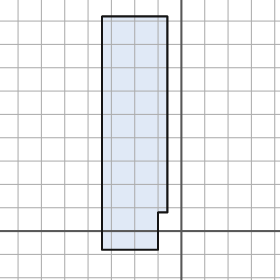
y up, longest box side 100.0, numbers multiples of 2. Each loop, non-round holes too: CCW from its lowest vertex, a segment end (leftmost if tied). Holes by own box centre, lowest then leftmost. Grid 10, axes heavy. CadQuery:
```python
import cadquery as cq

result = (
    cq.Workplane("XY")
    .moveTo(-34.0, -8.0)
    .lineTo(-10.0, -8.0)
    .lineTo(-10.0, 8.0)
    .lineTo(-6.0, 8.0)
    .lineTo(-6.0, 92.0)
    .lineTo(-34.0, 92.0)
    .close()
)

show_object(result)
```